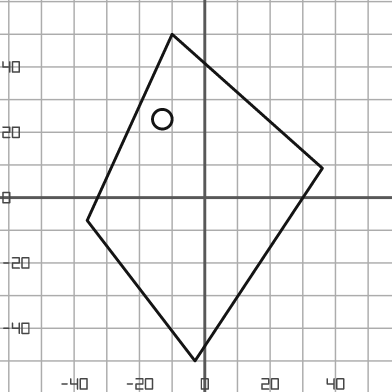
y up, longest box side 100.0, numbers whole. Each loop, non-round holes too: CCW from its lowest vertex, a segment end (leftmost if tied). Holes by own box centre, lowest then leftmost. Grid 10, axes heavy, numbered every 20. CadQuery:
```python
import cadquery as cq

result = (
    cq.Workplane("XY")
    .moveTo(-3.0, -50.0)
    .lineTo(36.0, 9.0)
    .lineTo(-10.0, 50.0)
    .lineTo(-36.0, -7.0)
    .close()
    .moveTo(-13.0, 24.0)
    .circle(3.0)
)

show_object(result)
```